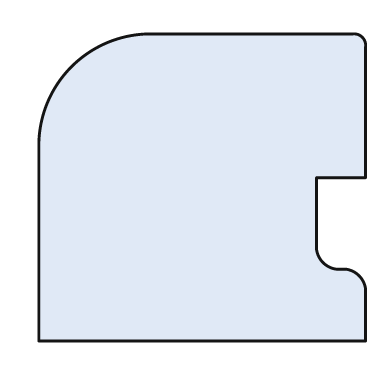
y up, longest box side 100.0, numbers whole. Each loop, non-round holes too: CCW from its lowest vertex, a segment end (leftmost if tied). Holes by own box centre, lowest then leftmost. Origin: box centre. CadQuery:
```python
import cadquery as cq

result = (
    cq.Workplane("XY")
    .moveTo(-50.0, -47.0)
    .lineTo(50.0, -47.0)
    .lineTo(50.0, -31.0)
    .threePointArc((48.0, -27.0), (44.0, -25.0))
    .lineTo(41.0, -25.0)
    .threePointArc((37.0, -23.0), (35.0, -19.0))
    .lineTo(35.0, 3.0)
    .lineTo(50.0, 3.0)
    .lineTo(50.0, 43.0)
    .threePointArc((49.0, 46.0), (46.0, 47.0))
    .lineTo(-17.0, 47.0)
    .threePointArc((-40.0, 37.0), (-50.0, 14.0))
    .close()
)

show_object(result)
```